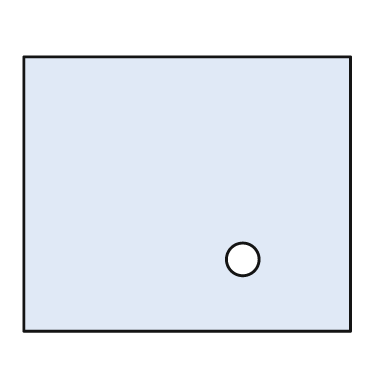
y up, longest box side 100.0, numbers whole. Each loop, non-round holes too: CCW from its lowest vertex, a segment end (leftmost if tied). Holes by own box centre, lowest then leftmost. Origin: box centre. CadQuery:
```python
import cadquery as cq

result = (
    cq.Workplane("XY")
    .moveTo(-50.0, -42.0)
    .lineTo(50.0, -42.0)
    .lineTo(50.0, 42.0)
    .lineTo(-50.0, 42.0)
    .close()
    .moveTo(17.0, -20.0)
    .circle(5.0)
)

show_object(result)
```